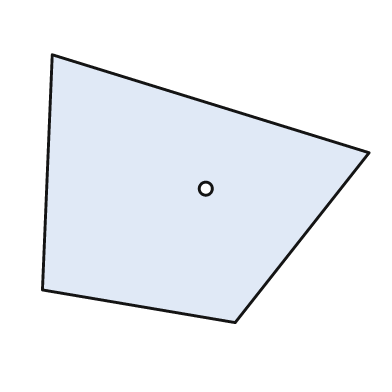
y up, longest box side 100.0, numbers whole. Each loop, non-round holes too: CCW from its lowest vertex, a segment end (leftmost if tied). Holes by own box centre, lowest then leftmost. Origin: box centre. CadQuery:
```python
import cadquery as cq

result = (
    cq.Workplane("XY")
    .moveTo(9.0, -41.0)
    .lineTo(50.0, 11.0)
    .lineTo(-47.0, 41.0)
    .lineTo(-50.0, -31.0)
    .close()
    .moveTo(0.0, 0.0)
    .circle(2.0)
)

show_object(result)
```